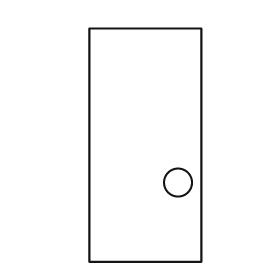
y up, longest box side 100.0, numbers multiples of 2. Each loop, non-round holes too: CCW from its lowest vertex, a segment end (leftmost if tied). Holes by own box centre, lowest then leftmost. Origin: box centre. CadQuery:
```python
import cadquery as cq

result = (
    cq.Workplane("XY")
    .moveTo(-24.0, -50.0)
    .lineTo(24.0, -50.0)
    .lineTo(24.0, 50.0)
    .lineTo(-24.0, 50.0)
    .close()
    .moveTo(14.0, -16.0)
    .circle(6.0)
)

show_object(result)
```